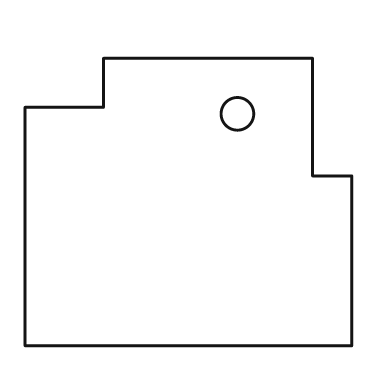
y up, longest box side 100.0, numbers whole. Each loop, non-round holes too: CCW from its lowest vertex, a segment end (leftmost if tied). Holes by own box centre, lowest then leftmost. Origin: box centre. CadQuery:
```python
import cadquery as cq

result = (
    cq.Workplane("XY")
    .moveTo(-50.0, -44.0)
    .lineTo(50.0, -44.0)
    .lineTo(50.0, 8.0)
    .lineTo(38.0, 8.0)
    .lineTo(38.0, 44.0)
    .lineTo(-26.0, 44.0)
    .lineTo(-26.0, 29.0)
    .lineTo(-50.0, 29.0)
    .close()
    .moveTo(15.0, 27.0)
    .circle(5.0)
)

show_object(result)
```